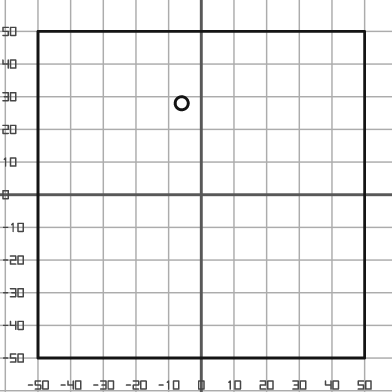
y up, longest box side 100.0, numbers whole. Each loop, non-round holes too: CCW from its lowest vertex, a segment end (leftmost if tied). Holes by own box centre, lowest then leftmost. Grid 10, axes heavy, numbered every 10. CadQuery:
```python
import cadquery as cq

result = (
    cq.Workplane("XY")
    .moveTo(-50.0, -50.0)
    .lineTo(50.0, -50.0)
    .lineTo(50.0, 50.0)
    .lineTo(-50.0, 50.0)
    .close()
    .moveTo(-6.0, 28.0)
    .circle(2.0)
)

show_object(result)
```